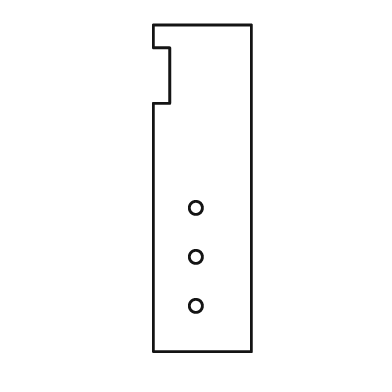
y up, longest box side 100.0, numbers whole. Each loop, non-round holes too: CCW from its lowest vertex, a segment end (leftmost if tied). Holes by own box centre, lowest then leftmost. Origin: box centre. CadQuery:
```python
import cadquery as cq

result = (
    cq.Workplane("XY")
    .moveTo(-15.0, -50.0)
    .lineTo(15.0, -50.0)
    .lineTo(15.0, 50.0)
    .lineTo(-15.0, 50.0)
    .lineTo(-15.0, 43.0)
    .lineTo(-10.0, 43.0)
    .lineTo(-10.0, 26.0)
    .lineTo(-15.0, 26.0)
    .close()
    .moveTo(-2.0, -36.0)
    .circle(2.0)
    .moveTo(-2.0, -21.0)
    .circle(2.0)
    .moveTo(-2.0, -6.0)
    .circle(2.0)
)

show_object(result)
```